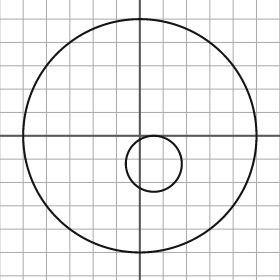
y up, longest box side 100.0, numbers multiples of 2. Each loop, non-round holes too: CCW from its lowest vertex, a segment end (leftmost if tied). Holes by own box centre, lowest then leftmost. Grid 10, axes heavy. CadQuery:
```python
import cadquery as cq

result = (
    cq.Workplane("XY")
    .moveTo(0.0, 0.0)
    .circle(50.0)
    .moveTo(6.0, -12.0)
    .circle(12.0)
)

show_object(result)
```